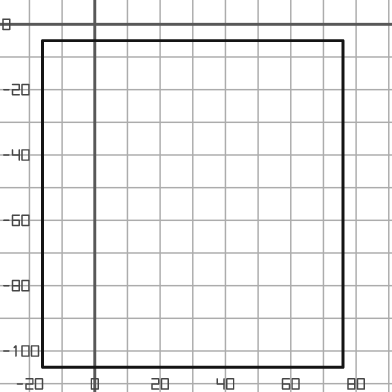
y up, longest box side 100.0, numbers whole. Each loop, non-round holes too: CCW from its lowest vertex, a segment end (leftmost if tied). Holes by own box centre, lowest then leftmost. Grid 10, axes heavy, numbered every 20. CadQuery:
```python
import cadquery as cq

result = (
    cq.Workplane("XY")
    .moveTo(-16.0, -105.0)
    .lineTo(76.0, -105.0)
    .lineTo(76.0, -5.0)
    .lineTo(-16.0, -5.0)
    .close()
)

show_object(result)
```